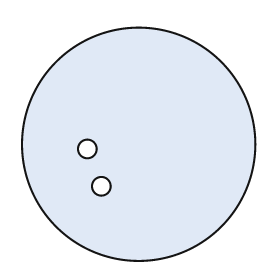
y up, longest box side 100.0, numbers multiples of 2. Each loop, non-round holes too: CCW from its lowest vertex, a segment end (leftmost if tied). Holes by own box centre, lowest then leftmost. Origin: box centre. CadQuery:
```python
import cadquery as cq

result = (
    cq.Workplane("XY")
    .moveTo(0.0, 0.0)
    .circle(50.0)
    .moveTo(-16.0, -18.0)
    .circle(4.0)
    .moveTo(-22.0, -2.0)
    .circle(4.0)
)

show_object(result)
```